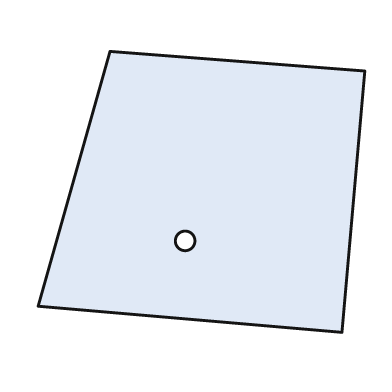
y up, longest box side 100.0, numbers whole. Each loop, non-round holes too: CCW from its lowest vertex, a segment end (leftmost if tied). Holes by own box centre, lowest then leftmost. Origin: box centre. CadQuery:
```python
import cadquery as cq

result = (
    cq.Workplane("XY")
    .moveTo(43.0, -43.0)
    .lineTo(50.0, 37.0)
    .lineTo(-28.0, 43.0)
    .lineTo(-50.0, -35.0)
    .close()
    .moveTo(-5.0, -15.0)
    .circle(3.0)
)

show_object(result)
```